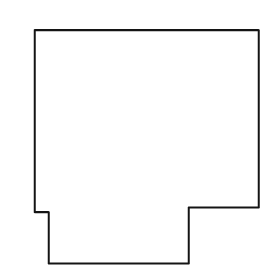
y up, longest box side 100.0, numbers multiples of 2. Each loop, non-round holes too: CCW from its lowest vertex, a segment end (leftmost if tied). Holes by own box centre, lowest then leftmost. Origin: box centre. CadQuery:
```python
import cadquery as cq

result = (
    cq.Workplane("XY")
    .moveTo(-42.0, -50.0)
    .lineTo(18.0, -50.0)
    .lineTo(18.0, -26.0)
    .lineTo(48.0, -26.0)
    .lineTo(48.0, 50.0)
    .lineTo(-48.0, 50.0)
    .lineTo(-48.0, -28.0)
    .lineTo(-42.0, -28.0)
    .close()
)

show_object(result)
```